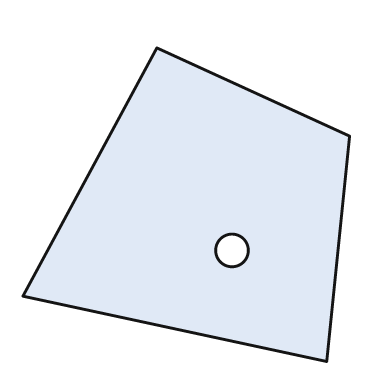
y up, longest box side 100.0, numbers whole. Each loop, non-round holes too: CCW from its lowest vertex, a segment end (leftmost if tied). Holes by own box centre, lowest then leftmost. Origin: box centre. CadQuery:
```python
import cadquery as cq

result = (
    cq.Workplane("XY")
    .moveTo(43.0, -48.0)
    .lineTo(50.0, 21.0)
    .lineTo(-9.0, 48.0)
    .lineTo(-50.0, -28.0)
    .close()
    .moveTo(14.0, -14.0)
    .circle(5.0)
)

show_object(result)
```